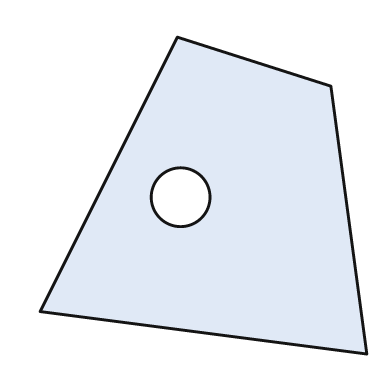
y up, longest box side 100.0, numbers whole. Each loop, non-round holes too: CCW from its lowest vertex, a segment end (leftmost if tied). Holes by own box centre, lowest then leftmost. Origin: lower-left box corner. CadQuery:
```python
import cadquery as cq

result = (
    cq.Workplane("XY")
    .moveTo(100.0, 0.0)
    .lineTo(89.0, 82.0)
    .lineTo(42.0, 97.0)
    .lineTo(0.0, 13.0)
    .close()
    .moveTo(43.0, 48.0)
    .circle(9.0)
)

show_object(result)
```